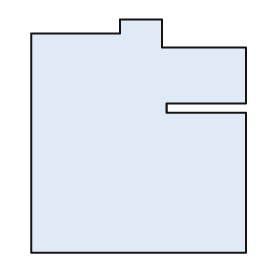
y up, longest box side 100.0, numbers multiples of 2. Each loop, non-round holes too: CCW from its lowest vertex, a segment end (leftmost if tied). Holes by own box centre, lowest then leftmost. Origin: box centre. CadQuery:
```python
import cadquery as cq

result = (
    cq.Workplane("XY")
    .moveTo(-46.0, -50.0)
    .lineTo(46.0, -50.0)
    .lineTo(46.0, 10.0)
    .lineTo(12.0, 10.0)
    .lineTo(12.0, 14.0)
    .lineTo(46.0, 14.0)
    .lineTo(46.0, 38.0)
    .lineTo(10.0, 38.0)
    .lineTo(10.0, 50.0)
    .lineTo(-8.0, 50.0)
    .lineTo(-8.0, 44.0)
    .lineTo(-46.0, 44.0)
    .close()
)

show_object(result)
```